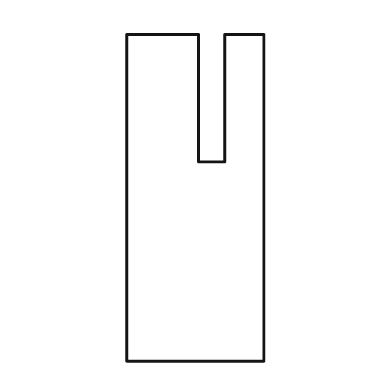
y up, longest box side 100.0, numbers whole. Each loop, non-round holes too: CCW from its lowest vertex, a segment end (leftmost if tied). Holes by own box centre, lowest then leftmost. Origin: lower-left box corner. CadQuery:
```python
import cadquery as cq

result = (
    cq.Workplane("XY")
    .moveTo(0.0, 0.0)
    .lineTo(42.0, 0.0)
    .lineTo(42.0, 100.0)
    .lineTo(30.0, 100.0)
    .lineTo(30.0, 61.0)
    .lineTo(22.0, 61.0)
    .lineTo(22.0, 100.0)
    .lineTo(0.0, 100.0)
    .close()
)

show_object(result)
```